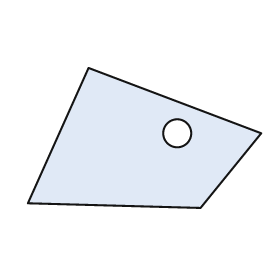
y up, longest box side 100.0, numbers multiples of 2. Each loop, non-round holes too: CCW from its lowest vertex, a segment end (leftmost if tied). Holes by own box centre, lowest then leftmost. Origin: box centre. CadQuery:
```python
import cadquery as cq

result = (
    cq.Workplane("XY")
    .moveTo(24.0, -30.0)
    .lineTo(50.0, 2.0)
    .lineTo(-24.0, 30.0)
    .lineTo(-50.0, -28.0)
    .close()
    .moveTo(14.0, 2.0)
    .circle(6.0)
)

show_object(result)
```